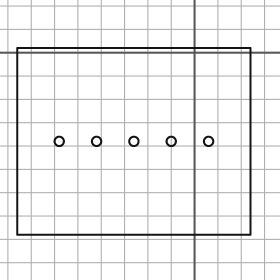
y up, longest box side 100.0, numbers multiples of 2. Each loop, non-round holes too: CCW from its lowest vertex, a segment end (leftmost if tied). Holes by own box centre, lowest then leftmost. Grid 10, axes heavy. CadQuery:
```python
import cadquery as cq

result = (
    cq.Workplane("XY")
    .moveTo(-76.0, -78.0)
    .lineTo(24.0, -78.0)
    .lineTo(24.0, 2.0)
    .lineTo(-76.0, 2.0)
    .close()
    .moveTo(-58.0, -38.0)
    .circle(2.0)
    .moveTo(-42.0, -38.0)
    .circle(2.0)
    .moveTo(-26.0, -38.0)
    .circle(2.0)
    .moveTo(-10.0, -38.0)
    .circle(2.0)
    .moveTo(6.0, -38.0)
    .circle(2.0)
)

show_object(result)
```